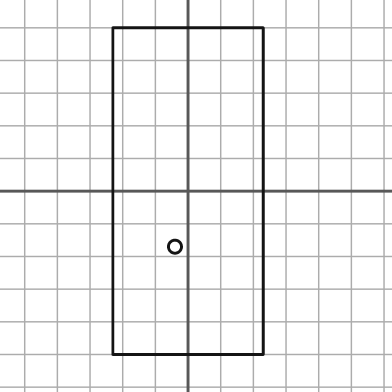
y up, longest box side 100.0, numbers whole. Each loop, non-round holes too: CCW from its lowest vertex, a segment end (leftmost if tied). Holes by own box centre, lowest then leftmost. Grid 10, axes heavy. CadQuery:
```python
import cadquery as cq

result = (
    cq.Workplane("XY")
    .moveTo(-23.0, -50.0)
    .lineTo(23.0, -50.0)
    .lineTo(23.0, 50.0)
    .lineTo(-23.0, 50.0)
    .close()
    .moveTo(-4.0, -17.0)
    .circle(2.0)
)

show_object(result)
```